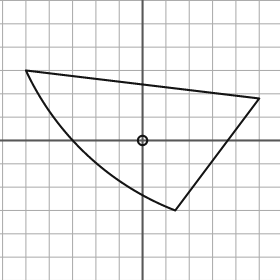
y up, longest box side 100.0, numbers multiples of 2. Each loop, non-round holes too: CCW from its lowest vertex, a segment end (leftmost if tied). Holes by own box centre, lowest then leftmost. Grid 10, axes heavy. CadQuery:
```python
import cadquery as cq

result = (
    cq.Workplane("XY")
    .moveTo(14.0, -30.0)
    .lineTo(50.0, 18.0)
    .lineTo(-50.0, 30.0)
    .threePointArc((-24.0, -6.0), (14.0, -30.0))
    .close()
    .moveTo(0.0, 0.0)
    .circle(2.0)
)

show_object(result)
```